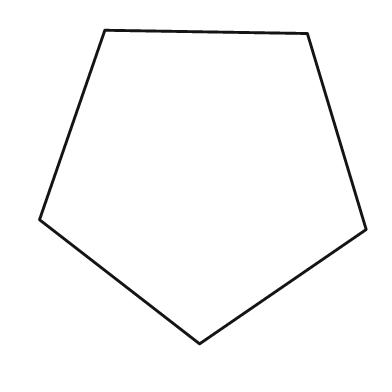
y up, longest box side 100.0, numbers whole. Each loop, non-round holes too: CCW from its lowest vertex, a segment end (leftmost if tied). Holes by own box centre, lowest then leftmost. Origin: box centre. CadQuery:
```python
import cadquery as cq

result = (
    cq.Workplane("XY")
    .moveTo(-1.0, -48.0)
    .lineTo(50.0, -13.0)
    .lineTo(32.0, 47.0)
    .lineTo(-30.0, 48.0)
    .lineTo(-50.0, -10.0)
    .close()
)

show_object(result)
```